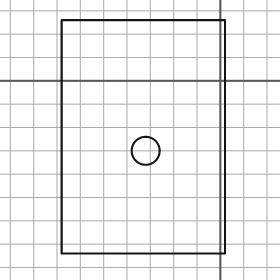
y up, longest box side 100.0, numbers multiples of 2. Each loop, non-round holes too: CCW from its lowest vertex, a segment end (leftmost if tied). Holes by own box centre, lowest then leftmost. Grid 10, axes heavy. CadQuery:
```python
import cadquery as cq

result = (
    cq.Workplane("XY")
    .moveTo(-68.0, -74.0)
    .lineTo(2.0, -74.0)
    .lineTo(2.0, 26.0)
    .lineTo(-68.0, 26.0)
    .close()
    .moveTo(-32.0, -30.0)
    .circle(6.0)
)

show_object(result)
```